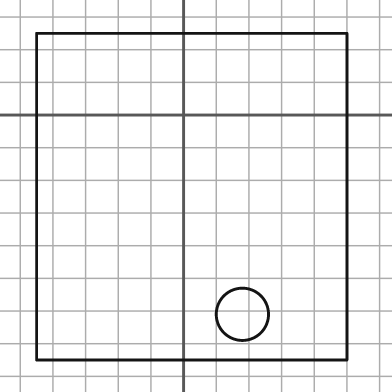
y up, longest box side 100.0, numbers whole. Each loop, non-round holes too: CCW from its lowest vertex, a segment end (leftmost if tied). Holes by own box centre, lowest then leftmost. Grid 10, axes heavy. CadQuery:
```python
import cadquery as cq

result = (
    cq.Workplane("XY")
    .moveTo(-45.0, -75.0)
    .lineTo(50.0, -75.0)
    .lineTo(50.0, 25.0)
    .lineTo(-45.0, 25.0)
    .close()
    .moveTo(18.0, -61.0)
    .circle(8.0)
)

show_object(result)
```